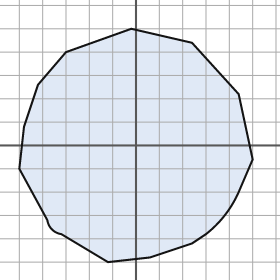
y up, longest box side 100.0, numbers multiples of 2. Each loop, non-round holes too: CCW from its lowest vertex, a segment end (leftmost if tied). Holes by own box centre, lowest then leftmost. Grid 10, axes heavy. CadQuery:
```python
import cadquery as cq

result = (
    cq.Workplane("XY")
    .moveTo(-12.0, -50.0)
    .lineTo(6.0, -48.0)
    .lineTo(24.0, -42.0)
    .lineTo(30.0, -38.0)
    .threePointArc((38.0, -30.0), (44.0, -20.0))
    .lineTo(50.0, -6.0)
    .lineTo(44.0, 22.0)
    .lineTo(24.0, 44.0)
    .lineTo(-2.0, 50.0)
    .lineTo(-30.0, 40.0)
    .lineTo(-42.0, 26.0)
    .lineTo(-48.0, 8.0)
    .lineTo(-50.0, -10.0)
    .lineTo(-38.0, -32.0)
    .threePointArc((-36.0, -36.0), (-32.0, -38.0))
    .close()
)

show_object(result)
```